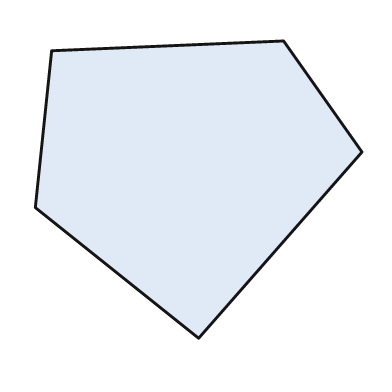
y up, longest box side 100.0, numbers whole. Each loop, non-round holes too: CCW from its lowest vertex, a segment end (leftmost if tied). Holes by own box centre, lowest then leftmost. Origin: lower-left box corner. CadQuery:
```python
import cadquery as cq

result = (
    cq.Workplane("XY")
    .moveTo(50.0, 0.0)
    .lineTo(100.0, 57.0)
    .lineTo(76.0, 91.0)
    .lineTo(5.0, 88.0)
    .lineTo(0.0, 40.0)
    .close()
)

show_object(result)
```